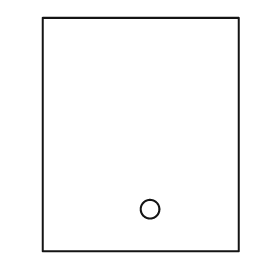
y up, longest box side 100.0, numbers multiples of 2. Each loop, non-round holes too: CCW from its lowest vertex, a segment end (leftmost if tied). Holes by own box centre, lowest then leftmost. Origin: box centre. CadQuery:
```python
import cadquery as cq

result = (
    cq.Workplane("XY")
    .moveTo(-42.0, -50.0)
    .lineTo(42.0, -50.0)
    .lineTo(42.0, 50.0)
    .lineTo(-42.0, 50.0)
    .close()
    .moveTo(4.0, -32.0)
    .circle(4.0)
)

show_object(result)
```